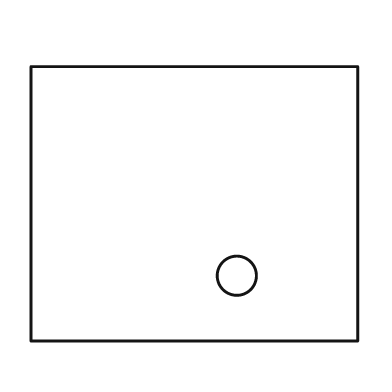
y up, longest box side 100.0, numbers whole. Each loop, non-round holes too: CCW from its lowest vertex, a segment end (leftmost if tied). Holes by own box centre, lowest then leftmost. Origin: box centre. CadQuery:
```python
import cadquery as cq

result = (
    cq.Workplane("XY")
    .moveTo(-50.0, -42.0)
    .lineTo(50.0, -42.0)
    .lineTo(50.0, 42.0)
    .lineTo(-50.0, 42.0)
    .close()
    .moveTo(13.0, -22.0)
    .circle(6.0)
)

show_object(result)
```